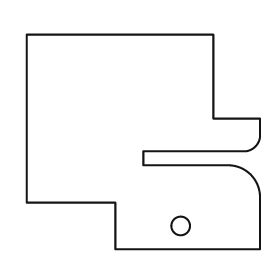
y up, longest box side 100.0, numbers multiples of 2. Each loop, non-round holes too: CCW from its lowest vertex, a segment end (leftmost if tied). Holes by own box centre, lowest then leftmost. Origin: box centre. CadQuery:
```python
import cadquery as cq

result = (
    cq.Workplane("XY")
    .moveTo(-12.0, -46.0)
    .lineTo(50.0, -46.0)
    .lineTo(50.0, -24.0)
    .threePointArc((46.0, -14.0), (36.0, -10.0))
    .lineTo(0.0, -10.0)
    .lineTo(0.0, -4.0)
    .lineTo(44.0, -4.0)
    .threePointArc((48.0, -2.0), (50.0, 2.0))
    .lineTo(50.0, 10.0)
    .lineTo(30.0, 10.0)
    .lineTo(30.0, 46.0)
    .lineTo(-50.0, 46.0)
    .lineTo(-50.0, -26.0)
    .lineTo(-12.0, -26.0)
    .close()
    .moveTo(16.0, -36.0)
    .circle(4.0)
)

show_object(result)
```